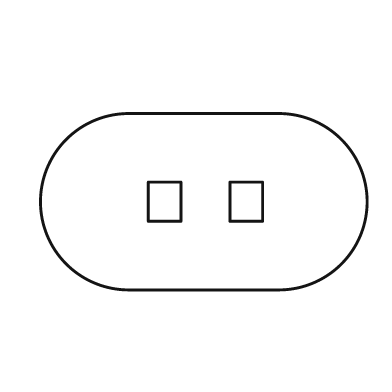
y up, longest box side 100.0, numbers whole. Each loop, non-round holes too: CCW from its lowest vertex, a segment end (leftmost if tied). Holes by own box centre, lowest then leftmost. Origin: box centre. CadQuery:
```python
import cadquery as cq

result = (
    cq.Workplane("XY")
    .moveTo(-23.0, -27.0)
    .lineTo(23.0, -27.0)
    .threePointArc((50.0, 0.0), (23.0, 27.0))
    .lineTo(-23.0, 27.0)
    .threePointArc((-50.0, 0.0), (-23.0, -27.0))
    .close()
    .moveTo(-17.0, -6.0)
    .lineTo(-7.0, -6.0)
    .lineTo(-7.0, 6.0)
    .lineTo(-17.0, 6.0)
    .close()
    .moveTo(8.0, -6.0)
    .lineTo(18.0, -6.0)
    .lineTo(18.0, 6.0)
    .lineTo(8.0, 6.0)
    .close()
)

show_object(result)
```